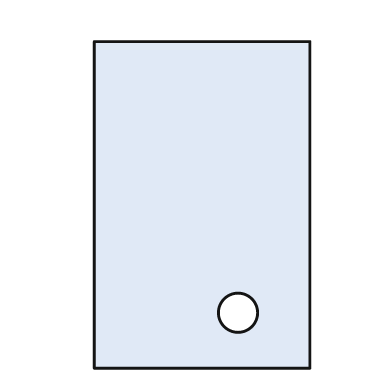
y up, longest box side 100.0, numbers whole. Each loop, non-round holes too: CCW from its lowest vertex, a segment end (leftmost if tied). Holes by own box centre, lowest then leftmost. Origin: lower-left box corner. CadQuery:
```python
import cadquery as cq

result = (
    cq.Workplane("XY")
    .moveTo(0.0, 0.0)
    .lineTo(66.0, 0.0)
    .lineTo(66.0, 100.0)
    .lineTo(0.0, 100.0)
    .close()
    .moveTo(44.0, 17.0)
    .circle(6.0)
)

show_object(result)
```